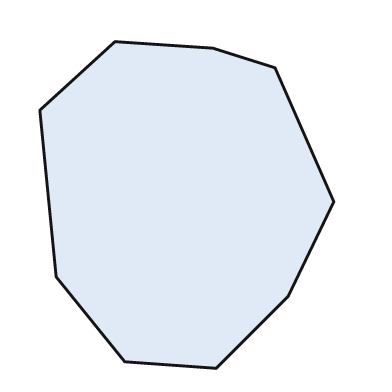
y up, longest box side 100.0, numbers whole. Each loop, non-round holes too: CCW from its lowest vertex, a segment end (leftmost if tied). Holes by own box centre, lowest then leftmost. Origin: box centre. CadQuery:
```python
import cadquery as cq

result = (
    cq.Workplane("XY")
    .moveTo(9.0, -50.0)
    .lineTo(31.0, -28.0)
    .lineTo(45.0, 1.0)
    .lineTo(27.0, 42.0)
    .lineTo(8.0, 48.0)
    .lineTo(-22.0, 50.0)
    .lineTo(-45.0, 29.0)
    .lineTo(-40.0, -22.0)
    .lineTo(-19.0, -48.0)
    .close()
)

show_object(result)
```